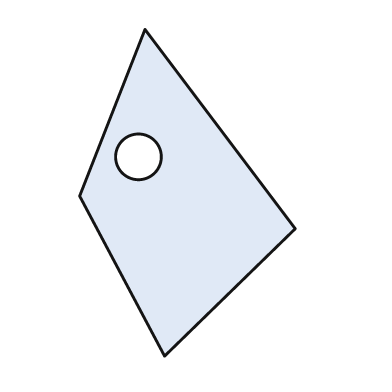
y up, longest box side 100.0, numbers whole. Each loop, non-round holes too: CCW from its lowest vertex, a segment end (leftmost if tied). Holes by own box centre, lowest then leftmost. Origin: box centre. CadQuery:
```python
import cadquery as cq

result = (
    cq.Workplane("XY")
    .moveTo(-7.0, -50.0)
    .lineTo(33.0, -11.0)
    .lineTo(-13.0, 50.0)
    .lineTo(-33.0, -1.0)
    .close()
    .moveTo(-15.0, 11.0)
    .circle(7.0)
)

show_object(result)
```